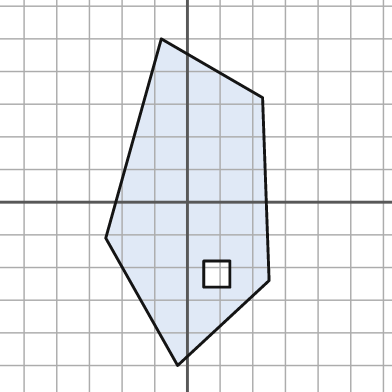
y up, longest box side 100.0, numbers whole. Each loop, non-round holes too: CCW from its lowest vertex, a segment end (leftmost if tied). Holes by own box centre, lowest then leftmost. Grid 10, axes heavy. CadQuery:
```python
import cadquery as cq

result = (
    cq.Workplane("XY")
    .moveTo(-3.0, -50.0)
    .lineTo(25.0, -24.0)
    .lineTo(23.0, 32.0)
    .lineTo(-8.0, 50.0)
    .lineTo(-25.0, -11.0)
    .close()
    .moveTo(5.0, -26.0)
    .lineTo(13.0, -26.0)
    .lineTo(13.0, -18.0)
    .lineTo(5.0, -18.0)
    .close()
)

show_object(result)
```